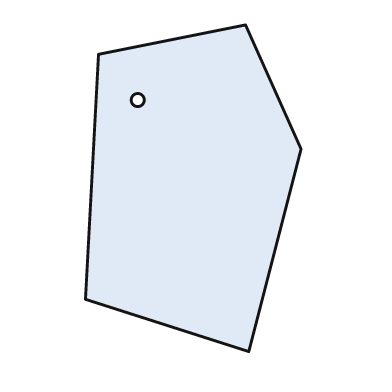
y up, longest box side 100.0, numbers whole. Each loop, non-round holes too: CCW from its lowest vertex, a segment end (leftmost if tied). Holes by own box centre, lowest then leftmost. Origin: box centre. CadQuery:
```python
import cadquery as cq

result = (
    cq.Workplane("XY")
    .moveTo(17.0, -50.0)
    .lineTo(33.0, 12.0)
    .lineTo(16.0, 50.0)
    .lineTo(-29.0, 41.0)
    .lineTo(-33.0, -34.0)
    .close()
    .moveTo(-17.0, 27.0)
    .circle(2.0)
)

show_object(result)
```